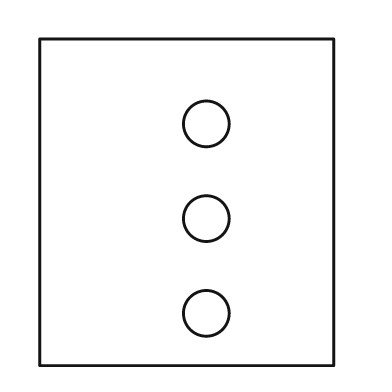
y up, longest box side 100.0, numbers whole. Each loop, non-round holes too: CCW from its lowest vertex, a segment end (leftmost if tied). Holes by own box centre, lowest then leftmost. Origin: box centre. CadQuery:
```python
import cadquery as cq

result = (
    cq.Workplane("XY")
    .moveTo(-45.0, -50.0)
    .lineTo(45.0, -50.0)
    .lineTo(45.0, 50.0)
    .lineTo(-45.0, 50.0)
    .close()
    .moveTo(6.0, -34.0)
    .circle(7.0)
    .moveTo(6.0, -5.0)
    .circle(7.0)
    .moveTo(6.0, 24.0)
    .circle(7.0)
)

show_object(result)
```